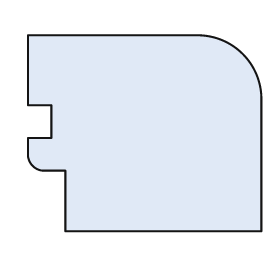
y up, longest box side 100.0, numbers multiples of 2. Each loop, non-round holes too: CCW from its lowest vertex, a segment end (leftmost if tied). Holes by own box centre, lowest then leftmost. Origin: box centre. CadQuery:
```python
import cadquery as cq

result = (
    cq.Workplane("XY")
    .moveTo(-34.0, -42.0)
    .lineTo(50.0, -42.0)
    .lineTo(50.0, 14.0)
    .threePointArc((42.0, 34.0), (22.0, 42.0))
    .lineTo(-50.0, 42.0)
    .lineTo(-50.0, 12.0)
    .lineTo(-40.0, 12.0)
    .lineTo(-40.0, -2.0)
    .lineTo(-50.0, -2.0)
    .lineTo(-50.0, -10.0)
    .threePointArc((-48.0, -14.0), (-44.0, -16.0))
    .lineTo(-34.0, -16.0)
    .close()
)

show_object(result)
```